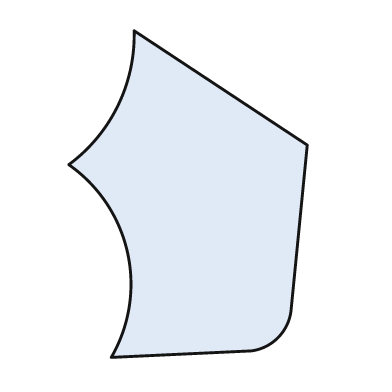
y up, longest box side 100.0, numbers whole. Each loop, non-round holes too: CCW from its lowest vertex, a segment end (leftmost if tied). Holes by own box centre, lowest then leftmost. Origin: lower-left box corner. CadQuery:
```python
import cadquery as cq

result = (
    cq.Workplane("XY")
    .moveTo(13.0, 0.0)
    .lineTo(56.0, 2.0)
    .threePointArc((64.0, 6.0), (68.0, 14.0))
    .lineTo(73.0, 65.0)
    .lineTo(20.0, 100.0)
    .threePointArc((15.0, 77.0), (0.0, 59.0))
    .threePointArc((18.0, 32.0), (13.0, 0.0))
    .close()
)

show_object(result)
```